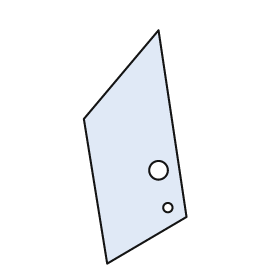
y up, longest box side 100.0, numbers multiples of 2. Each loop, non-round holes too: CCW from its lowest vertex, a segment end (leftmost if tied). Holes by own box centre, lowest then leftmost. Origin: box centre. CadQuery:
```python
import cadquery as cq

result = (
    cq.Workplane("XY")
    .moveTo(-12.0, -50.0)
    .lineTo(22.0, -30.0)
    .lineTo(10.0, 50.0)
    .lineTo(-22.0, 12.0)
    .close()
    .moveTo(14.0, -26.0)
    .circle(2.0)
    .moveTo(10.0, -10.0)
    .circle(4.0)
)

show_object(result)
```